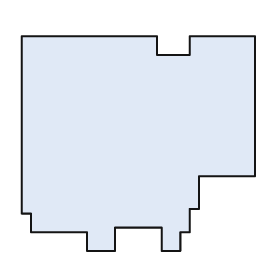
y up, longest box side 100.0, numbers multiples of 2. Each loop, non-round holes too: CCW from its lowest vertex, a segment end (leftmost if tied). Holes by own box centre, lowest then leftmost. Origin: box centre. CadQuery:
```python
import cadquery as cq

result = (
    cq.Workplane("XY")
    .moveTo(-22.0, -46.0)
    .lineTo(-10.0, -46.0)
    .lineTo(-10.0, -36.0)
    .lineTo(10.0, -36.0)
    .lineTo(10.0, -46.0)
    .lineTo(18.0, -46.0)
    .lineTo(18.0, -38.0)
    .lineTo(22.0, -38.0)
    .lineTo(22.0, -28.0)
    .lineTo(26.0, -28.0)
    .lineTo(26.0, -14.0)
    .lineTo(50.0, -14.0)
    .lineTo(50.0, 46.0)
    .lineTo(22.0, 46.0)
    .lineTo(22.0, 38.0)
    .lineTo(8.0, 38.0)
    .lineTo(8.0, 46.0)
    .lineTo(-50.0, 46.0)
    .lineTo(-50.0, -30.0)
    .lineTo(-46.0, -30.0)
    .lineTo(-46.0, -38.0)
    .lineTo(-22.0, -38.0)
    .close()
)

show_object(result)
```